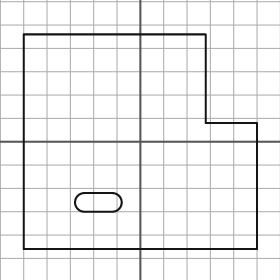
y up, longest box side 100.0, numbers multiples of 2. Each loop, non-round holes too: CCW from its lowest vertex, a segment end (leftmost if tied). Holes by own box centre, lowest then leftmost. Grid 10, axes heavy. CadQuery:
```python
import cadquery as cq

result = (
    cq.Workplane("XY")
    .moveTo(-50.0, -46.0)
    .lineTo(50.0, -46.0)
    .lineTo(50.0, 8.0)
    .lineTo(28.0, 8.0)
    .lineTo(28.0, 46.0)
    .lineTo(-50.0, 46.0)
    .close()
    .moveTo(-24.0, -30.0)
    .lineTo(-12.0, -30.0)
    .threePointArc((-8.0, -26.0), (-12.0, -22.0))
    .lineTo(-24.0, -22.0)
    .threePointArc((-28.0, -26.0), (-24.0, -30.0))
    .close()
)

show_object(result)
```